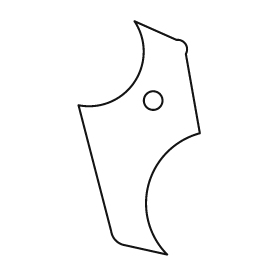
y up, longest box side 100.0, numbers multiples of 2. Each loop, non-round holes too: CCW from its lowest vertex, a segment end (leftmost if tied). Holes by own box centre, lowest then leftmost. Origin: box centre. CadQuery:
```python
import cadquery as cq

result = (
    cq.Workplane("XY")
    .moveTo(12.0, -50.0)
    .threePointArc((4.0, -20.0), (26.0, 2.0))
    .lineTo(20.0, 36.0)
    .threePointArc((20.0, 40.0), (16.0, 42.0))
    .lineTo(-2.0, 50.0)
    .threePointArc((-2.0, 24.0), (-26.0, 14.0))
    .lineTo(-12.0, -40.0)
    .threePointArc((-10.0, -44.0), (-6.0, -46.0))
    .close()
    .moveTo(6.0, 16.0)
    .circle(4.0)
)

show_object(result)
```